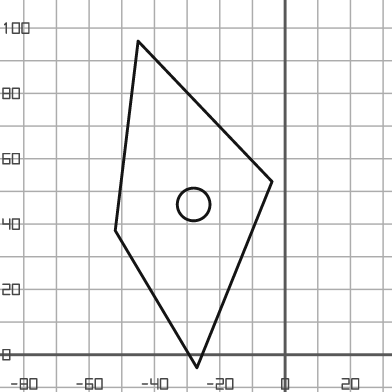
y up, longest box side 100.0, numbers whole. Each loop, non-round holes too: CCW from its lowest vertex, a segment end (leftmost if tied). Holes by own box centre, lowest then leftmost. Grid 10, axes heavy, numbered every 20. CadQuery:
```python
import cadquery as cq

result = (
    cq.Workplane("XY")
    .moveTo(-27.0, -4.0)
    .lineTo(-4.0, 53.0)
    .lineTo(-45.0, 96.0)
    .lineTo(-52.0, 38.0)
    .close()
    .moveTo(-28.0, 46.0)
    .circle(5.0)
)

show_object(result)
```